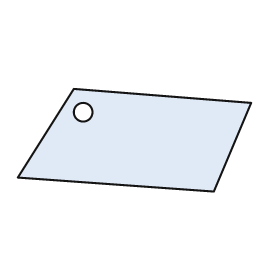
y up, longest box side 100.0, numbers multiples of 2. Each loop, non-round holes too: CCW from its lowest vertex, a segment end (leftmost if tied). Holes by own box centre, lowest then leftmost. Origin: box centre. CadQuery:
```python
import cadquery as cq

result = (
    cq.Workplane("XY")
    .moveTo(34.0, -22.0)
    .lineTo(50.0, 16.0)
    .lineTo(-26.0, 22.0)
    .lineTo(-50.0, -16.0)
    .close()
    .moveTo(-22.0, 12.0)
    .circle(4.0)
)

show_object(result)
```